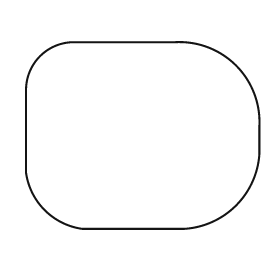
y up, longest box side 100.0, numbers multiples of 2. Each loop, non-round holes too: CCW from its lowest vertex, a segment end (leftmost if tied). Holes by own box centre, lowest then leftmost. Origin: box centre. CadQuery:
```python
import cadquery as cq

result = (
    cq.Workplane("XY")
    .moveTo(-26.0, -40.0)
    .lineTo(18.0, -40.0)
    .threePointArc((40.0, -30.0), (50.0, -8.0))
    .lineTo(50.0, 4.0)
    .threePointArc((40.0, 30.0), (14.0, 40.0))
    .lineTo(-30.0, 40.0)
    .threePointArc((-44.0, 34.0), (-50.0, 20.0))
    .lineTo(-50.0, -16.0)
    .threePointArc((-42.0, -32.0), (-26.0, -40.0))
    .close()
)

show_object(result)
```